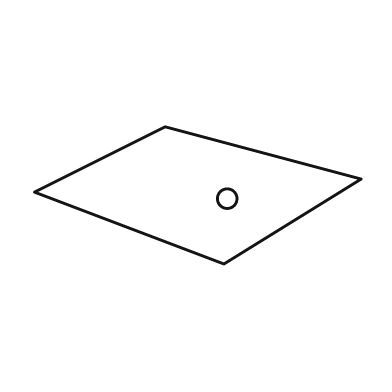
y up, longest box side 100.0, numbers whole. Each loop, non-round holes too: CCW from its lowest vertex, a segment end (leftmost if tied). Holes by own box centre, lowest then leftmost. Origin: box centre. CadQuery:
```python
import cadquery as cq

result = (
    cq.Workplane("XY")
    .moveTo(8.0, -21.0)
    .lineTo(50.0, 5.0)
    .lineTo(-10.0, 21.0)
    .lineTo(-50.0, 1.0)
    .close()
    .moveTo(9.0, -1.0)
    .circle(3.0)
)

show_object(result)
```